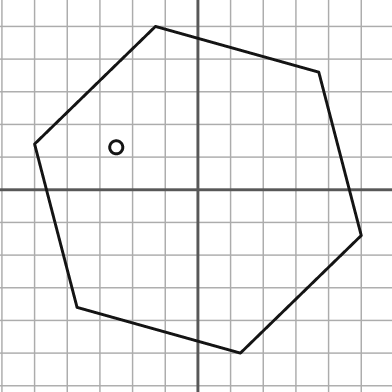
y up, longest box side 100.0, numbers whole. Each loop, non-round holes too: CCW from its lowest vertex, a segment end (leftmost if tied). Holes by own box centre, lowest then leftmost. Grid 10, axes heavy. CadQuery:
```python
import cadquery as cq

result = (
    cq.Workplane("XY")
    .moveTo(13.0, -50.0)
    .lineTo(50.0, -14.0)
    .lineTo(37.0, 36.0)
    .lineTo(-13.0, 50.0)
    .lineTo(-50.0, 14.0)
    .lineTo(-37.0, -36.0)
    .close()
    .moveTo(-25.0, 13.0)
    .circle(2.0)
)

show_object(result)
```